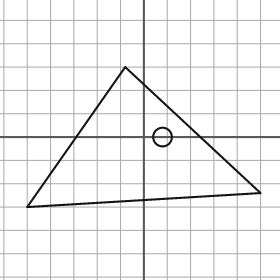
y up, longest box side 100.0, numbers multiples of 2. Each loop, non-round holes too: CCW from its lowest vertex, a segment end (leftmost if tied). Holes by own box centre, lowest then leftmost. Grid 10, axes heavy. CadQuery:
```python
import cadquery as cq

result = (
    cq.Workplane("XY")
    .moveTo(-50.0, -30.0)
    .lineTo(50.0, -24.0)
    .lineTo(-8.0, 30.0)
    .close()
    .moveTo(8.0, 0.0)
    .circle(4.0)
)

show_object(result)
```